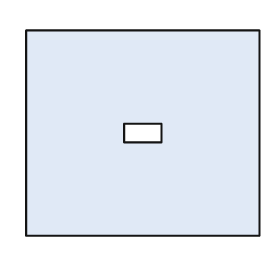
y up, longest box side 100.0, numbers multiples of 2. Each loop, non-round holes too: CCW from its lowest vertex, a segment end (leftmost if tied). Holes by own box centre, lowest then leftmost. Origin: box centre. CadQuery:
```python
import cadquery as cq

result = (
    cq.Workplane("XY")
    .moveTo(-50.0, -44.0)
    .lineTo(50.0, -44.0)
    .lineTo(50.0, 44.0)
    .lineTo(-50.0, 44.0)
    .close()
    .moveTo(-8.0, -4.0)
    .lineTo(8.0, -4.0)
    .lineTo(8.0, 4.0)
    .lineTo(-8.0, 4.0)
    .close()
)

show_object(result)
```